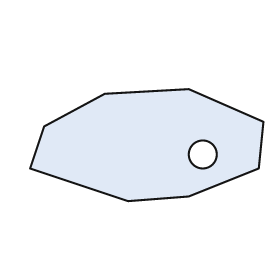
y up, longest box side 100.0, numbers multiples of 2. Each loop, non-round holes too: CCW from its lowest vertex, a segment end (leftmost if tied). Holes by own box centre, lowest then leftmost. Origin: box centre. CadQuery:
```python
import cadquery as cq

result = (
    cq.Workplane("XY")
    .moveTo(-8.0, -24.0)
    .lineTo(18.0, -22.0)
    .lineTo(48.0, -10.0)
    .lineTo(50.0, 10.0)
    .lineTo(18.0, 24.0)
    .lineTo(-18.0, 22.0)
    .lineTo(-44.0, 8.0)
    .lineTo(-50.0, -10.0)
    .close()
    .moveTo(24.0, -4.0)
    .circle(6.0)
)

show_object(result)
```